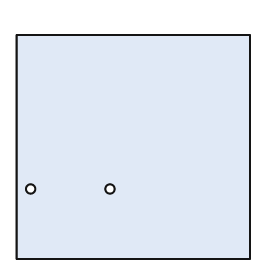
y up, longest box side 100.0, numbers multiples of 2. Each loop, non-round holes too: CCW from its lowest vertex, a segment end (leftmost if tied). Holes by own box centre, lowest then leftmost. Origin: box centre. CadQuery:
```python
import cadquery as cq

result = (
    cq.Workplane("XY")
    .moveTo(-50.0, -48.0)
    .lineTo(50.0, -48.0)
    .lineTo(50.0, 48.0)
    .lineTo(-50.0, 48.0)
    .close()
    .moveTo(-44.0, -18.0)
    .circle(2.0)
    .moveTo(-10.0, -18.0)
    .circle(2.0)
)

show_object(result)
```